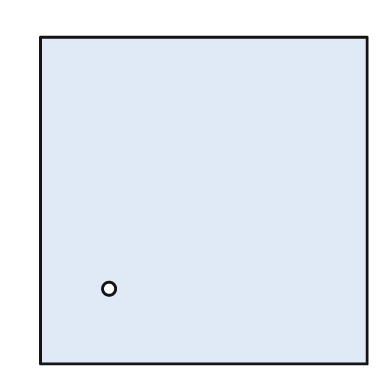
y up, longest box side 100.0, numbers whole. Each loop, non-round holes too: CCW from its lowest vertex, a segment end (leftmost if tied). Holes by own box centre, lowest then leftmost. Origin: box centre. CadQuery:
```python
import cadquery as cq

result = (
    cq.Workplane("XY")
    .moveTo(-50.0, -50.0)
    .lineTo(50.0, -50.0)
    .lineTo(50.0, 50.0)
    .lineTo(-50.0, 50.0)
    .close()
    .moveTo(-29.0, -27.0)
    .circle(2.0)
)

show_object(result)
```